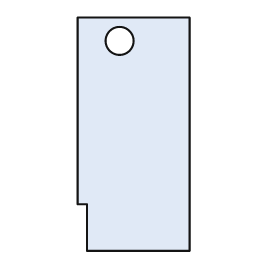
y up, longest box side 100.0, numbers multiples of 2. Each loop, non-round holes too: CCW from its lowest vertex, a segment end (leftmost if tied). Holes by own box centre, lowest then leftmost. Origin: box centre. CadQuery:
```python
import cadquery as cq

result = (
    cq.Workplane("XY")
    .moveTo(-20.0, -50.0)
    .lineTo(24.0, -50.0)
    .lineTo(24.0, 50.0)
    .lineTo(-24.0, 50.0)
    .lineTo(-24.0, -30.0)
    .lineTo(-20.0, -30.0)
    .close()
    .moveTo(-6.0, 40.0)
    .circle(6.0)
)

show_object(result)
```